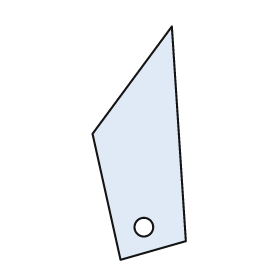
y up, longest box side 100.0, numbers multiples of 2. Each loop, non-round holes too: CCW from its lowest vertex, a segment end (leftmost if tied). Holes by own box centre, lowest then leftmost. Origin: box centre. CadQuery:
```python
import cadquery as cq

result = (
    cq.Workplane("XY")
    .moveTo(-8.0, -50.0)
    .lineTo(20.0, -42.0)
    .lineTo(14.0, 50.0)
    .lineTo(-20.0, 4.0)
    .close()
    .moveTo(2.0, -36.0)
    .circle(4.0)
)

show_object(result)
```